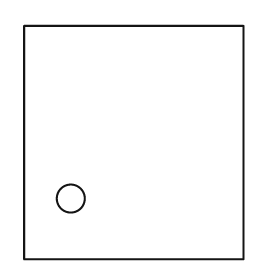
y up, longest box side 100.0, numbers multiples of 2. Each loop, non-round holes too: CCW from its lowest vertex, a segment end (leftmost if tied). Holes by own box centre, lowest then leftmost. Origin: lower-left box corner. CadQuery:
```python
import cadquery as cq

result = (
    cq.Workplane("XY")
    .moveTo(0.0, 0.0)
    .lineTo(94.0, 0.0)
    .lineTo(94.0, 100.0)
    .lineTo(0.0, 100.0)
    .close()
    .moveTo(20.0, 26.0)
    .circle(6.0)
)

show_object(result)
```